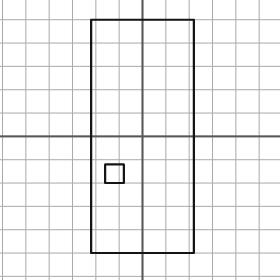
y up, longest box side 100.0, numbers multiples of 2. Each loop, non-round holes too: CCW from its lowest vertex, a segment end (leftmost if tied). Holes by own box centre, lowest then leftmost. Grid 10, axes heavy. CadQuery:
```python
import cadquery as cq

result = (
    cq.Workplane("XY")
    .moveTo(-22.0, -50.0)
    .lineTo(22.0, -50.0)
    .lineTo(22.0, 50.0)
    .lineTo(-22.0, 50.0)
    .close()
    .moveTo(-16.0, -20.0)
    .lineTo(-8.0, -20.0)
    .lineTo(-8.0, -12.0)
    .lineTo(-16.0, -12.0)
    .close()
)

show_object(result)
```